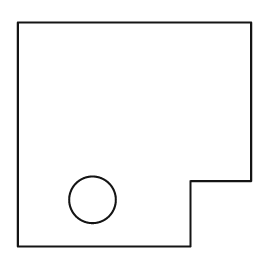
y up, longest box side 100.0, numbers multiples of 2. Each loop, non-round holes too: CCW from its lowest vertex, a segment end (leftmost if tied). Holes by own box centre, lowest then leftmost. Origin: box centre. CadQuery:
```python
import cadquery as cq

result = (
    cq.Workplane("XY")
    .moveTo(-50.0, -48.0)
    .lineTo(24.0, -48.0)
    .lineTo(24.0, -20.0)
    .lineTo(50.0, -20.0)
    .lineTo(50.0, 48.0)
    .lineTo(-50.0, 48.0)
    .close()
    .moveTo(-18.0, -28.0)
    .circle(10.0)
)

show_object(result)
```